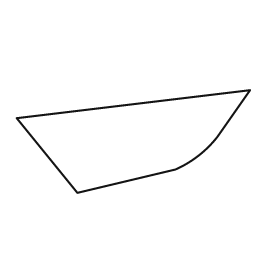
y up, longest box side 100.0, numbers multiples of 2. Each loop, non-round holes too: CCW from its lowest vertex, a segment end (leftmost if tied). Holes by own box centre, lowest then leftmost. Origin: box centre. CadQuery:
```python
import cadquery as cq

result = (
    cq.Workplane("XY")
    .moveTo(-24.0, -22.0)
    .lineTo(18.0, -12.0)
    .threePointArc((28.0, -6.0), (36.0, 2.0))
    .lineTo(50.0, 22.0)
    .lineTo(-50.0, 10.0)
    .close()
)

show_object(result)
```